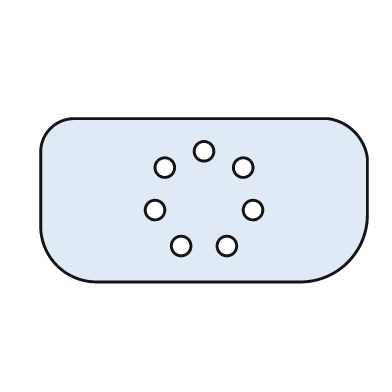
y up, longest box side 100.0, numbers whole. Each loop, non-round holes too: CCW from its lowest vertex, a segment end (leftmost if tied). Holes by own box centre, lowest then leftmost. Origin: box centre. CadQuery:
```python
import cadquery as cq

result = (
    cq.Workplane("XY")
    .moveTo(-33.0, -25.0)
    .lineTo(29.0, -25.0)
    .threePointArc((44.0, -19.0), (50.0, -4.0))
    .lineTo(50.0, 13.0)
    .threePointArc((46.0, 21.0), (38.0, 25.0))
    .lineTo(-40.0, 25.0)
    .threePointArc((-47.0, 22.0), (-50.0, 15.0))
    .lineTo(-50.0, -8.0)
    .threePointArc((-45.0, -20.0), (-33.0, -25.0))
    .close()
    .moveTo(-7.0, -14.0)
    .circle(3.0)
    .moveTo(7.0, -14.0)
    .circle(3.0)
    .moveTo(-15.0, -3.0)
    .circle(3.0)
    .moveTo(15.0, -3.0)
    .circle(3.0)
    .moveTo(-12.0, 10.0)
    .circle(3.0)
    .moveTo(12.0, 10.0)
    .circle(3.0)
    .moveTo(0.0, 15.0)
    .circle(3.0)
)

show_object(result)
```